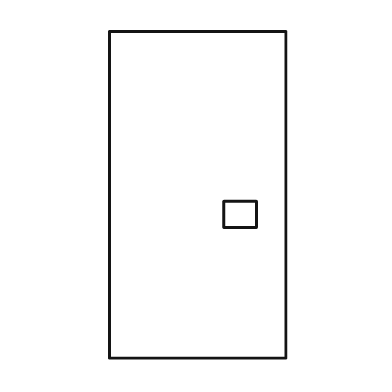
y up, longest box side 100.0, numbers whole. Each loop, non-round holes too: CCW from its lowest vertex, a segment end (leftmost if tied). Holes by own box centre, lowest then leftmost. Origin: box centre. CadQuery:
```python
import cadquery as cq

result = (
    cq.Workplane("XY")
    .moveTo(-27.0, -50.0)
    .lineTo(27.0, -50.0)
    .lineTo(27.0, 50.0)
    .lineTo(-27.0, 50.0)
    .close()
    .moveTo(8.0, -10.0)
    .lineTo(18.0, -10.0)
    .lineTo(18.0, -2.0)
    .lineTo(8.0, -2.0)
    .close()
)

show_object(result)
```